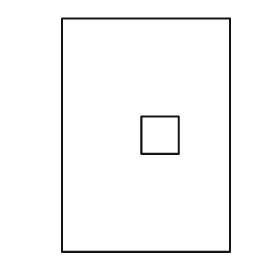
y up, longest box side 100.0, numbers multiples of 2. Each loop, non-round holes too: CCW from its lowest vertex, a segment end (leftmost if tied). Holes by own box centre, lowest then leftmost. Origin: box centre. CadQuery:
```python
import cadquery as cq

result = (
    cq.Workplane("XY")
    .moveTo(-36.0, -50.0)
    .lineTo(36.0, -50.0)
    .lineTo(36.0, 50.0)
    .lineTo(-36.0, 50.0)
    .close()
    .moveTo(-2.0, -8.0)
    .lineTo(14.0, -8.0)
    .lineTo(14.0, 8.0)
    .lineTo(-2.0, 8.0)
    .close()
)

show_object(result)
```